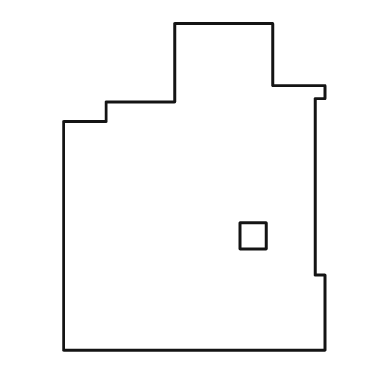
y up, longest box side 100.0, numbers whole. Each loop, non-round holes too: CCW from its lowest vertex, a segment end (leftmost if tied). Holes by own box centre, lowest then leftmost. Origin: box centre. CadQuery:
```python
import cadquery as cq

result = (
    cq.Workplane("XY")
    .moveTo(-40.0, -50.0)
    .lineTo(40.0, -50.0)
    .lineTo(40.0, -27.0)
    .lineTo(37.0, -27.0)
    .lineTo(37.0, 27.0)
    .lineTo(40.0, 27.0)
    .lineTo(40.0, 31.0)
    .lineTo(24.0, 31.0)
    .lineTo(24.0, 50.0)
    .lineTo(-6.0, 50.0)
    .lineTo(-6.0, 26.0)
    .lineTo(-27.0, 26.0)
    .lineTo(-27.0, 20.0)
    .lineTo(-40.0, 20.0)
    .close()
    .moveTo(14.0, -19.0)
    .lineTo(22.0, -19.0)
    .lineTo(22.0, -11.0)
    .lineTo(14.0, -11.0)
    .close()
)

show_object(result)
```